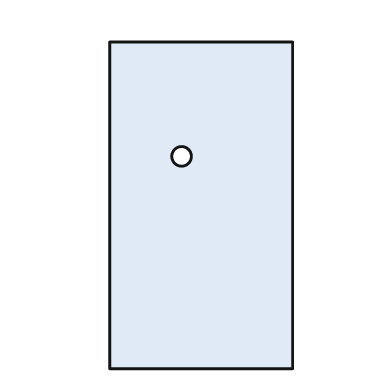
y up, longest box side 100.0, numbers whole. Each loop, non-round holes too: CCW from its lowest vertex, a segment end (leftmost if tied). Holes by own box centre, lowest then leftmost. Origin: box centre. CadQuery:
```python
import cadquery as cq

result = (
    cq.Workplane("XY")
    .moveTo(-28.0, -50.0)
    .lineTo(28.0, -50.0)
    .lineTo(28.0, 50.0)
    .lineTo(-28.0, 50.0)
    .close()
    .moveTo(-6.0, 15.0)
    .circle(3.0)
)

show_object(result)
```